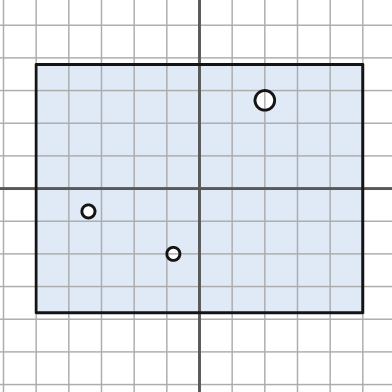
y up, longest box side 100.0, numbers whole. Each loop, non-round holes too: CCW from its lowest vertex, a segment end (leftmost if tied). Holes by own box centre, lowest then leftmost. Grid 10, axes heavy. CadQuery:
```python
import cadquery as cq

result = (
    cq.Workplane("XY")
    .moveTo(-50.0, -38.0)
    .lineTo(50.0, -38.0)
    .lineTo(50.0, 38.0)
    .lineTo(-50.0, 38.0)
    .close()
    .moveTo(-8.0, -20.0)
    .circle(2.0)
    .moveTo(-34.0, -7.0)
    .circle(2.0)
    .moveTo(20.0, 27.0)
    .circle(3.0)
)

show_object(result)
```